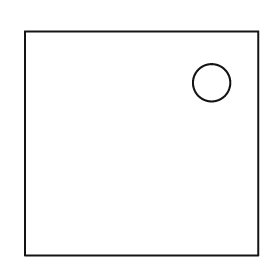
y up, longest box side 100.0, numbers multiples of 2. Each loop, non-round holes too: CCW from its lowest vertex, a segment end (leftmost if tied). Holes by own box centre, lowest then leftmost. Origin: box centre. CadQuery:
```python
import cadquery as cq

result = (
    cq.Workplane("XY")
    .moveTo(-50.0, -48.0)
    .lineTo(50.0, -48.0)
    .lineTo(50.0, 48.0)
    .lineTo(-50.0, 48.0)
    .close()
    .moveTo(30.0, 26.0)
    .circle(8.0)
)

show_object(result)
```